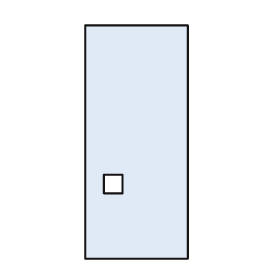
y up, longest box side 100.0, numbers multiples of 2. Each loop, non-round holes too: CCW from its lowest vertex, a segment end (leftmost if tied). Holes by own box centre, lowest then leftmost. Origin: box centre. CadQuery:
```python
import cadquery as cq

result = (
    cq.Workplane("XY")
    .moveTo(-22.0, -50.0)
    .lineTo(22.0, -50.0)
    .lineTo(22.0, 50.0)
    .lineTo(-22.0, 50.0)
    .close()
    .moveTo(-14.0, -22.0)
    .lineTo(-6.0, -22.0)
    .lineTo(-6.0, -14.0)
    .lineTo(-14.0, -14.0)
    .close()
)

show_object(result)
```